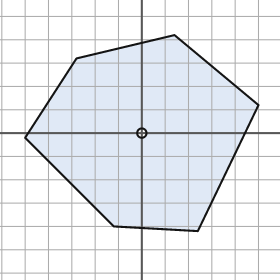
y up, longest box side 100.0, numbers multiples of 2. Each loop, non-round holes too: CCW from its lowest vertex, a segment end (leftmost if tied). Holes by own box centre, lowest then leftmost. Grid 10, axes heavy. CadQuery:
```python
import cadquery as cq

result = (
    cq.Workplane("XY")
    .moveTo(24.0, -42.0)
    .lineTo(50.0, 12.0)
    .lineTo(14.0, 42.0)
    .lineTo(-28.0, 32.0)
    .lineTo(-50.0, -2.0)
    .lineTo(-12.0, -40.0)
    .close()
    .moveTo(0.0, 0.0)
    .circle(2.0)
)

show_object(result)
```